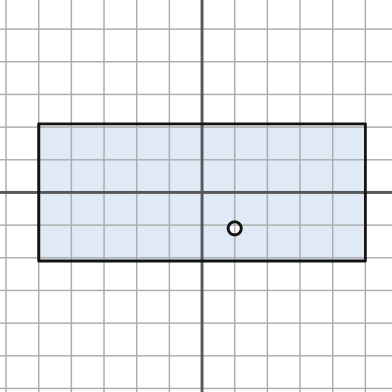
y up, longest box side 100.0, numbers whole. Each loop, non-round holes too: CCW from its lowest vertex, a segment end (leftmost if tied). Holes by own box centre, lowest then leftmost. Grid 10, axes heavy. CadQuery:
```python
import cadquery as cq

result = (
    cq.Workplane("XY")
    .moveTo(-50.0, -21.0)
    .lineTo(50.0, -21.0)
    .lineTo(50.0, 21.0)
    .lineTo(-50.0, 21.0)
    .close()
    .moveTo(10.0, -11.0)
    .circle(2.0)
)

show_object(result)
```